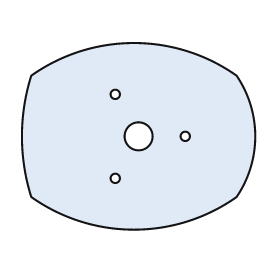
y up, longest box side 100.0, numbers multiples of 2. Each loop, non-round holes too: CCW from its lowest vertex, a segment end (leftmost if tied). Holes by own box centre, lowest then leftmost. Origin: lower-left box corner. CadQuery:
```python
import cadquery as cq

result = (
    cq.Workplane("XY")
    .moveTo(4.0, 14.0)
    .threePointArc((48.0, 0.0), (92.0, 14.0))
    .threePointArc((100.0, 40.0), (92.0, 66.0))
    .threePointArc((48.0, 80.0), (4.0, 66.0))
    .threePointArc((0.0, 40.0), (4.0, 14.0))
    .close()
    .moveTo(40.0, 22.0)
    .circle(2.0)
    .moveTo(50.0, 40.0)
    .circle(6.0)
    .moveTo(70.0, 40.0)
    .circle(2.0)
    .moveTo(40.0, 58.0)
    .circle(2.0)
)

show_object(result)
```